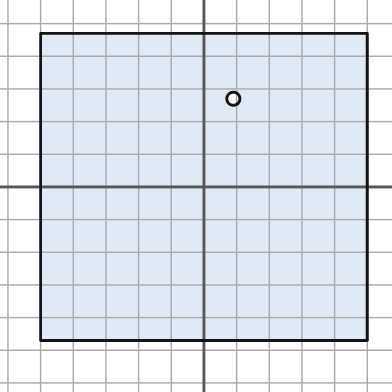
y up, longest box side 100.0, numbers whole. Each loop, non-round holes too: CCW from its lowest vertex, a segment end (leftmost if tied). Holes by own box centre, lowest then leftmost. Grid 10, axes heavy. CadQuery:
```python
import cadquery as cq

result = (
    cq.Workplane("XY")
    .moveTo(-50.0, -47.0)
    .lineTo(50.0, -47.0)
    .lineTo(50.0, 47.0)
    .lineTo(-50.0, 47.0)
    .close()
    .moveTo(9.0, 27.0)
    .circle(2.0)
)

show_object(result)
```